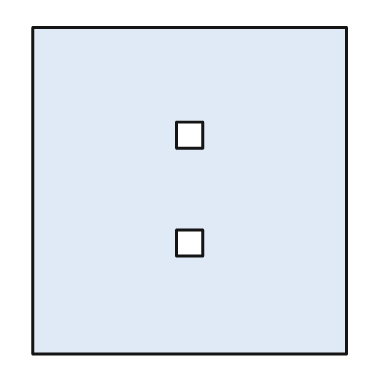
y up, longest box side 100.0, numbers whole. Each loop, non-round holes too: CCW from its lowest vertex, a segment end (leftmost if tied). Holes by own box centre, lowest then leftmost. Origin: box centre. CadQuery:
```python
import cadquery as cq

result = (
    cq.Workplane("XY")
    .moveTo(-48.0, -50.0)
    .lineTo(48.0, -50.0)
    .lineTo(48.0, 50.0)
    .lineTo(-48.0, 50.0)
    .close()
    .moveTo(-4.0, -20.0)
    .lineTo(4.0, -20.0)
    .lineTo(4.0, -12.0)
    .lineTo(-4.0, -12.0)
    .close()
    .moveTo(-4.0, 13.0)
    .lineTo(4.0, 13.0)
    .lineTo(4.0, 21.0)
    .lineTo(-4.0, 21.0)
    .close()
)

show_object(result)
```